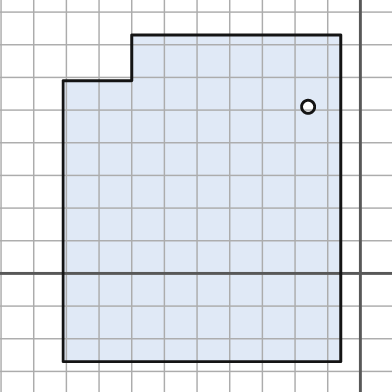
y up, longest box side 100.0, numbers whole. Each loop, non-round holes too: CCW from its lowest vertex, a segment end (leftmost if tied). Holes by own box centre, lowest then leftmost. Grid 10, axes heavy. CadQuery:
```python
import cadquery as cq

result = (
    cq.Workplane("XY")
    .moveTo(-91.0, -27.0)
    .lineTo(-6.0, -27.0)
    .lineTo(-6.0, 73.0)
    .lineTo(-70.0, 73.0)
    .lineTo(-70.0, 59.0)
    .lineTo(-91.0, 59.0)
    .close()
    .moveTo(-16.0, 51.0)
    .circle(2.0)
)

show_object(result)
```